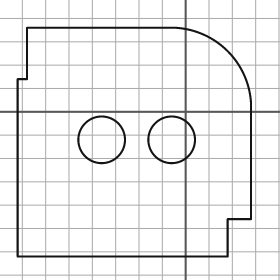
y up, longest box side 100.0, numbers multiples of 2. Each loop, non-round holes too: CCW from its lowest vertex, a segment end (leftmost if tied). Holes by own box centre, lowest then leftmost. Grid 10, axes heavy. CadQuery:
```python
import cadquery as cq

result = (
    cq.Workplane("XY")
    .moveTo(-72.0, -62.0)
    .lineTo(18.0, -62.0)
    .lineTo(18.0, -46.0)
    .lineTo(28.0, -46.0)
    .lineTo(28.0, 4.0)
    .threePointArc((18.0, 26.0), (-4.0, 36.0))
    .lineTo(-68.0, 36.0)
    .lineTo(-68.0, 14.0)
    .lineTo(-72.0, 14.0)
    .close()
    .moveTo(-36.0, -12.0)
    .circle(10.0)
    .moveTo(-6.0, -12.0)
    .circle(10.0)
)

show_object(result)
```